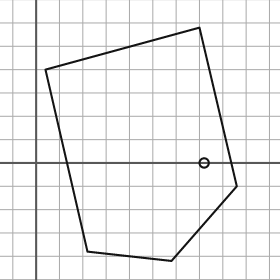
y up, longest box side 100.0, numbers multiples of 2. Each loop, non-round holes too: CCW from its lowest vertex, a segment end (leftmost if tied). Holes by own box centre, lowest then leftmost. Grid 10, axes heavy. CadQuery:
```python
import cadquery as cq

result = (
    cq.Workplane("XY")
    .moveTo(58.0, -42.0)
    .lineTo(86.0, -10.0)
    .lineTo(70.0, 58.0)
    .lineTo(4.0, 40.0)
    .lineTo(22.0, -38.0)
    .close()
    .moveTo(72.0, 0.0)
    .circle(2.0)
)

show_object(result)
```